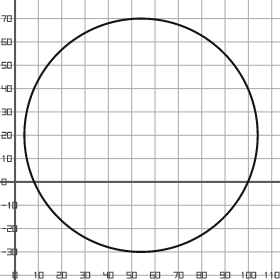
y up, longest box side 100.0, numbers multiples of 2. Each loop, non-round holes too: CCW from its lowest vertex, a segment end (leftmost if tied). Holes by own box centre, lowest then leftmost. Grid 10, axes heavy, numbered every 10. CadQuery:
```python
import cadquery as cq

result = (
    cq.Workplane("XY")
    .moveTo(54.0, 20.0)
    .circle(50.0)
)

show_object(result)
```